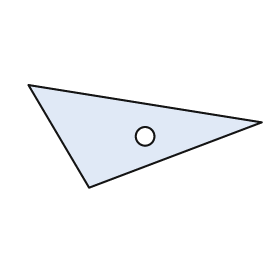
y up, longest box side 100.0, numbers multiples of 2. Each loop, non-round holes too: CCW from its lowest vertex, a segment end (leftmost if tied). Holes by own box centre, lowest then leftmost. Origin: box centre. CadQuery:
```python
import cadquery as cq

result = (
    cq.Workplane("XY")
    .moveTo(-24.0, -22.0)
    .lineTo(50.0, 6.0)
    .lineTo(-50.0, 22.0)
    .close()
    .moveTo(0.0, 0.0)
    .circle(4.0)
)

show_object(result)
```